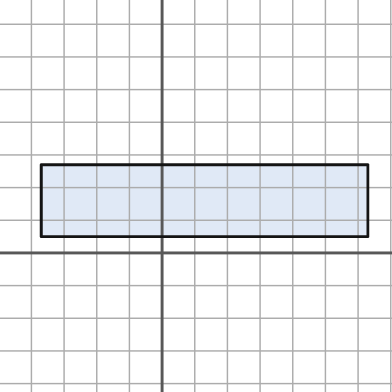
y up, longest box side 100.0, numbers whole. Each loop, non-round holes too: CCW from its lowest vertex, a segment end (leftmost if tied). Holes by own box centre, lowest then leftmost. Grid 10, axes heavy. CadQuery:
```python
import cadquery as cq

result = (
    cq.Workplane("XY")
    .moveTo(-37.0, 5.0)
    .lineTo(63.0, 5.0)
    .lineTo(63.0, 27.0)
    .lineTo(-37.0, 27.0)
    .close()
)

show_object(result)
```